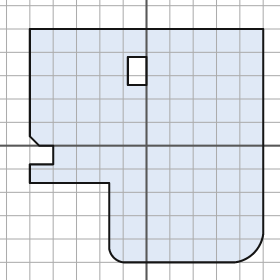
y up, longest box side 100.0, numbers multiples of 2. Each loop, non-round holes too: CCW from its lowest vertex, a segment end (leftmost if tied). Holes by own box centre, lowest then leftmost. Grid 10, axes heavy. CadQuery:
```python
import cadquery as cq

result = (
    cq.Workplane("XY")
    .moveTo(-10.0, -50.0)
    .lineTo(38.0, -50.0)
    .threePointArc((46.0, -46.0), (50.0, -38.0))
    .lineTo(50.0, 50.0)
    .lineTo(-50.0, 50.0)
    .lineTo(-50.0, 4.0)
    .lineTo(-46.0, 0.0)
    .lineTo(-40.0, 0.0)
    .lineTo(-40.0, -8.0)
    .lineTo(-50.0, -8.0)
    .lineTo(-50.0, -16.0)
    .lineTo(-16.0, -16.0)
    .lineTo(-16.0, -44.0)
    .threePointArc((-14.0, -48.0), (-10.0, -50.0))
    .close()
    .moveTo(-8.0, 26.0)
    .lineTo(0.0, 26.0)
    .lineTo(0.0, 38.0)
    .lineTo(-8.0, 38.0)
    .close()
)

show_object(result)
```